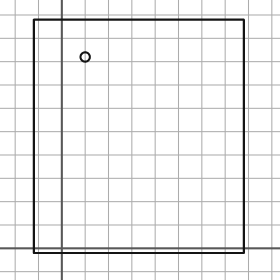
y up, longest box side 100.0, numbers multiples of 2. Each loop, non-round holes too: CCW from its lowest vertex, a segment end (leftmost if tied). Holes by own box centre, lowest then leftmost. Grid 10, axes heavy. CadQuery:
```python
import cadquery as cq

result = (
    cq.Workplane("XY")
    .moveTo(-12.0, -2.0)
    .lineTo(78.0, -2.0)
    .lineTo(78.0, 98.0)
    .lineTo(-12.0, 98.0)
    .close()
    .moveTo(10.0, 82.0)
    .circle(2.0)
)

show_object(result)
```